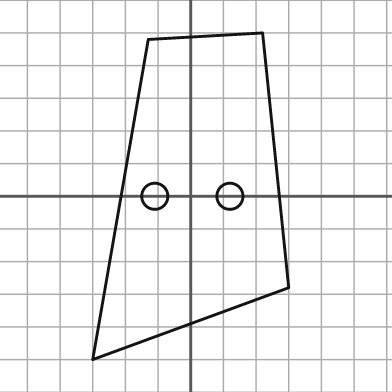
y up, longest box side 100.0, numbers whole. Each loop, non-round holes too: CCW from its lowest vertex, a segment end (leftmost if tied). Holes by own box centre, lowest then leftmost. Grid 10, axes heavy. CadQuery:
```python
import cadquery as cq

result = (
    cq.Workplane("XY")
    .moveTo(-30.0, -50.0)
    .lineTo(30.0, -28.0)
    .lineTo(22.0, 50.0)
    .lineTo(-13.0, 48.0)
    .close()
    .moveTo(-11.0, 0.0)
    .circle(4.0)
    .moveTo(12.0, 0.0)
    .circle(4.0)
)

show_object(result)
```